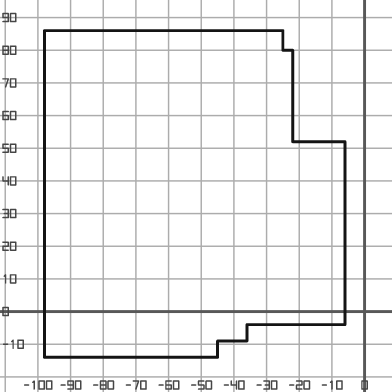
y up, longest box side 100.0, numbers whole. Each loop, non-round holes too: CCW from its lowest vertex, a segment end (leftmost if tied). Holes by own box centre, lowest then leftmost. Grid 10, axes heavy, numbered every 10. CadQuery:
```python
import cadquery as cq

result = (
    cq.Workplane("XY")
    .moveTo(-98.0, -14.0)
    .lineTo(-45.0, -14.0)
    .lineTo(-45.0, -9.0)
    .lineTo(-36.0, -9.0)
    .lineTo(-36.0, -4.0)
    .lineTo(-6.0, -4.0)
    .lineTo(-6.0, 52.0)
    .lineTo(-22.0, 52.0)
    .lineTo(-22.0, 80.0)
    .lineTo(-25.0, 80.0)
    .lineTo(-25.0, 86.0)
    .lineTo(-98.0, 86.0)
    .close()
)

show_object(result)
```